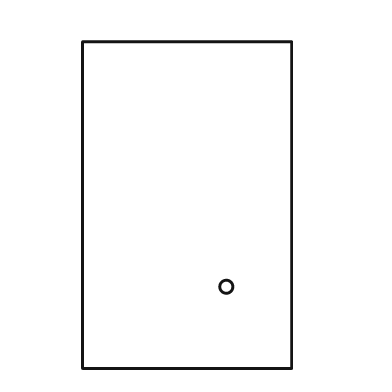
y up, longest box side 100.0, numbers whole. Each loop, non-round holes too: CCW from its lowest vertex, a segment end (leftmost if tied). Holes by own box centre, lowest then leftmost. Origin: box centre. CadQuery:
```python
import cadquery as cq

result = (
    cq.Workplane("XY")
    .moveTo(-32.0, -50.0)
    .lineTo(32.0, -50.0)
    .lineTo(32.0, 50.0)
    .lineTo(-32.0, 50.0)
    .close()
    .moveTo(12.0, -25.0)
    .circle(2.0)
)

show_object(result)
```